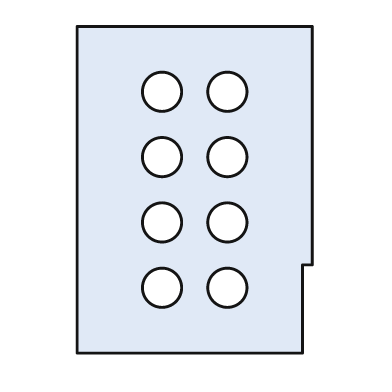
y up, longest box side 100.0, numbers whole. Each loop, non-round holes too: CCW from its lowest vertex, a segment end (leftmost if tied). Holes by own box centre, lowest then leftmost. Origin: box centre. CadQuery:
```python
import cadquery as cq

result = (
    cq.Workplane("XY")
    .moveTo(-36.0, -50.0)
    .lineTo(33.0, -50.0)
    .lineTo(33.0, -23.0)
    .lineTo(36.0, -23.0)
    .lineTo(36.0, 50.0)
    .lineTo(-36.0, 50.0)
    .close()
    .moveTo(-10.0, -30.0)
    .circle(6.0)
    .moveTo(10.0, -30.0)
    .circle(6.0)
    .moveTo(-10.0, -10.0)
    .circle(6.0)
    .moveTo(10.0, -10.0)
    .circle(6.0)
    .moveTo(-10.0, 10.0)
    .circle(6.0)
    .moveTo(10.0, 10.0)
    .circle(6.0)
    .moveTo(-10.0, 30.0)
    .circle(6.0)
    .moveTo(10.0, 30.0)
    .circle(6.0)
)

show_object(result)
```